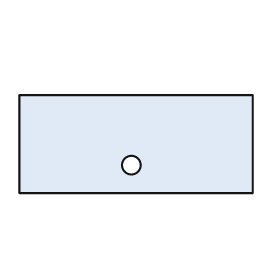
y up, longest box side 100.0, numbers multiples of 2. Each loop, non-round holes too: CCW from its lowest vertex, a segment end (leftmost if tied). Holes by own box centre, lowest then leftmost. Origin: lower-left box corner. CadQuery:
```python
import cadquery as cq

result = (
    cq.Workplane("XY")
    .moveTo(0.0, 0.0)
    .lineTo(100.0, 0.0)
    .lineTo(100.0, 42.0)
    .lineTo(0.0, 42.0)
    .close()
    .moveTo(48.0, 12.0)
    .circle(4.0)
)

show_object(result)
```